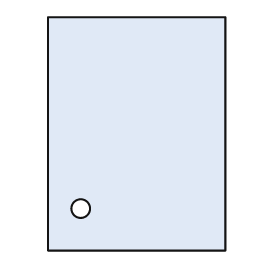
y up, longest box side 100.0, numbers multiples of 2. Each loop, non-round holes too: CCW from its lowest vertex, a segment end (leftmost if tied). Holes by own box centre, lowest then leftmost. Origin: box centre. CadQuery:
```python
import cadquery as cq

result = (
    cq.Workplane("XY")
    .moveTo(-38.0, -50.0)
    .lineTo(38.0, -50.0)
    .lineTo(38.0, 50.0)
    .lineTo(-38.0, 50.0)
    .close()
    .moveTo(-24.0, -32.0)
    .circle(4.0)
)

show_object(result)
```